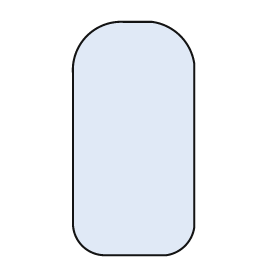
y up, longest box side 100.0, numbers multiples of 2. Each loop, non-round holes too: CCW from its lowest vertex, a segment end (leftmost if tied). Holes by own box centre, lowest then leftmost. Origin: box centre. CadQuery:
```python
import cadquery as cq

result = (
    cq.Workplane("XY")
    .moveTo(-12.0, -50.0)
    .lineTo(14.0, -50.0)
    .threePointArc((22.0, -46.0), (26.0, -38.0))
    .lineTo(26.0, 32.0)
    .threePointArc((20.0, 44.0), (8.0, 50.0))
    .lineTo(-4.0, 50.0)
    .threePointArc((-20.0, 44.0), (-26.0, 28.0))
    .lineTo(-26.0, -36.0)
    .threePointArc((-22.0, -46.0), (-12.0, -50.0))
    .close()
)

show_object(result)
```